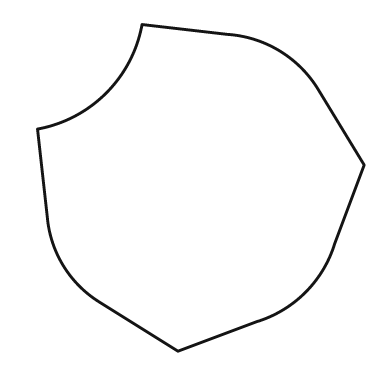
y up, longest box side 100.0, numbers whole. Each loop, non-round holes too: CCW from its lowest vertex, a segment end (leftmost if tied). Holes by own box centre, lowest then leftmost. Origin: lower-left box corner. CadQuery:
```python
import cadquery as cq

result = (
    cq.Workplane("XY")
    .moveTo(43.0, 0.0)
    .lineTo(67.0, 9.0)
    .threePointArc((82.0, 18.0), (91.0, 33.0))
    .lineTo(100.0, 57.0)
    .lineTo(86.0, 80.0)
    .threePointArc((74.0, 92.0), (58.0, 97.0))
    .lineTo(32.0, 100.0)
    .threePointArc((21.0, 79.0), (0.0, 68.0))
    .lineTo(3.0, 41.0)
    .threePointArc((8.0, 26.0), (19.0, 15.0))
    .close()
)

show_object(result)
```